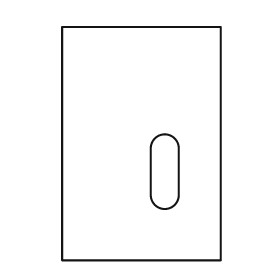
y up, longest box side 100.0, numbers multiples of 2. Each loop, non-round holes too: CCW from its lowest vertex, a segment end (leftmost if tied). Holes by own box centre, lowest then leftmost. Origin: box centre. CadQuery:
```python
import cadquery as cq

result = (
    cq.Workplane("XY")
    .moveTo(-34.0, -50.0)
    .lineTo(34.0, -50.0)
    .lineTo(34.0, 50.0)
    .lineTo(-34.0, 50.0)
    .close()
    .moveTo(4.0, -22.0)
    .threePointArc((10.0, -28.0), (16.0, -22.0))
    .lineTo(16.0, -2.0)
    .threePointArc((10.0, 4.0), (4.0, -2.0))
    .close()
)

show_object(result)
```